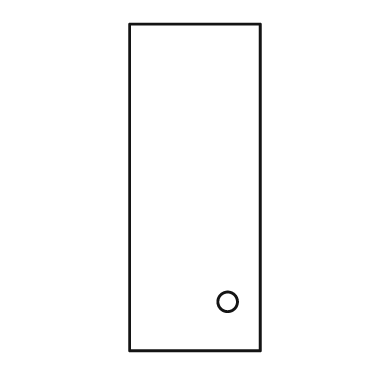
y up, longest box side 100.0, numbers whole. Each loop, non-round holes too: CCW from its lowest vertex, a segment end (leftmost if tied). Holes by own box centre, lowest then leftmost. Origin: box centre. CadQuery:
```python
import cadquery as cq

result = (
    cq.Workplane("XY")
    .moveTo(-20.0, -50.0)
    .lineTo(20.0, -50.0)
    .lineTo(20.0, 50.0)
    .lineTo(-20.0, 50.0)
    .close()
    .moveTo(10.0, -35.0)
    .circle(3.0)
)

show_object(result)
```